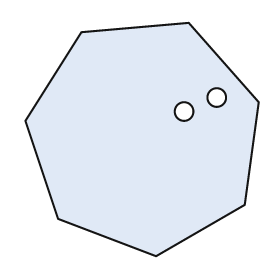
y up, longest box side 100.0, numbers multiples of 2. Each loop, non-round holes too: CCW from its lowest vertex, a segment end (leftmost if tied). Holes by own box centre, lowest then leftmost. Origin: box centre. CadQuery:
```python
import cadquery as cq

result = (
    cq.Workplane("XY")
    .moveTo(6.0, -50.0)
    .lineTo(44.0, -28.0)
    .lineTo(50.0, 16.0)
    .lineTo(20.0, 50.0)
    .lineTo(-26.0, 46.0)
    .lineTo(-50.0, 8.0)
    .lineTo(-36.0, -34.0)
    .close()
    .moveTo(18.0, 12.0)
    .circle(4.0)
    .moveTo(32.0, 18.0)
    .circle(4.0)
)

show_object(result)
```